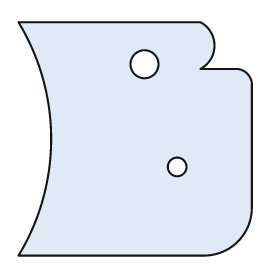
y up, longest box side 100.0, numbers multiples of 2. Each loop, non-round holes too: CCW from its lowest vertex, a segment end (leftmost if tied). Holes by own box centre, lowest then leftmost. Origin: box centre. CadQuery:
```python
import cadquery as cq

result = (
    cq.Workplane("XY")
    .moveTo(-50.0, -50.0)
    .lineTo(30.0, -50.0)
    .threePointArc((44.0, -44.0), (50.0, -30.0))
    .lineTo(50.0, 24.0)
    .threePointArc((48.0, 28.0), (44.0, 30.0))
    .lineTo(28.0, 30.0)
    .threePointArc((34.0, 40.0), (28.0, 50.0))
    .lineTo(-50.0, 50.0)
    .threePointArc((-36.0, 0.0), (-50.0, -50.0))
    .close()
    .moveTo(18.0, -12.0)
    .circle(4.0)
    .moveTo(4.0, 32.0)
    .circle(6.0)
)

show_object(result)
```